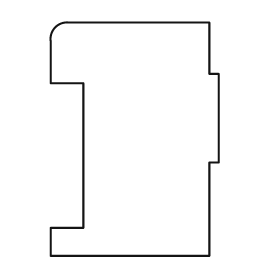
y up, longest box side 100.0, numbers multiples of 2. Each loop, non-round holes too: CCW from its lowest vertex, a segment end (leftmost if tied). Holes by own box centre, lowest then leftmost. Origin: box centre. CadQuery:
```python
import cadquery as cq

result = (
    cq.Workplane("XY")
    .moveTo(-36.0, -50.0)
    .lineTo(32.0, -50.0)
    .lineTo(32.0, -10.0)
    .lineTo(36.0, -10.0)
    .lineTo(36.0, 28.0)
    .lineTo(32.0, 28.0)
    .lineTo(32.0, 50.0)
    .lineTo(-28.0, 50.0)
    .threePointArc((-34.0, 48.0), (-36.0, 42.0))
    .lineTo(-36.0, 24.0)
    .lineTo(-22.0, 24.0)
    .lineTo(-22.0, -38.0)
    .lineTo(-36.0, -38.0)
    .close()
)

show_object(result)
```